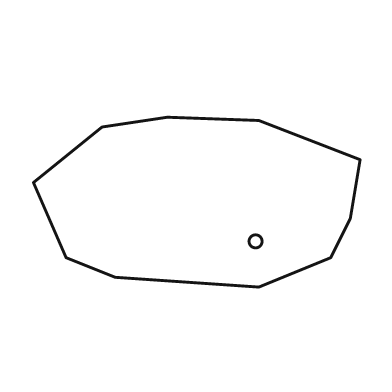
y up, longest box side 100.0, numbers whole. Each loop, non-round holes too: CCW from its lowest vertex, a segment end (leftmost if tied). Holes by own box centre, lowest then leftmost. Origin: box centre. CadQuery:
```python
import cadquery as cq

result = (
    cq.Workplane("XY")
    .moveTo(19.0, -26.0)
    .lineTo(41.0, -17.0)
    .lineTo(47.0, -5.0)
    .lineTo(50.0, 13.0)
    .lineTo(19.0, 25.0)
    .lineTo(-9.0, 26.0)
    .lineTo(-29.0, 23.0)
    .lineTo(-50.0, 6.0)
    .lineTo(-40.0, -17.0)
    .lineTo(-25.0, -23.0)
    .close()
    .moveTo(18.0, -12.0)
    .circle(2.0)
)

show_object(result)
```